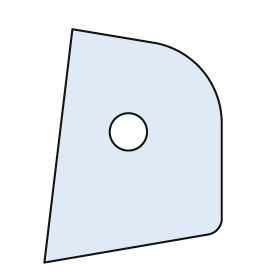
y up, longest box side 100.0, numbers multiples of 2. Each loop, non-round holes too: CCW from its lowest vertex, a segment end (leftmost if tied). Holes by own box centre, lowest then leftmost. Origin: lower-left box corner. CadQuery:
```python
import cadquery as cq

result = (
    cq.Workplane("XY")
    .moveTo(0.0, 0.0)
    .lineTo(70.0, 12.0)
    .threePointArc((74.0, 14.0), (76.0, 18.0))
    .lineTo(76.0, 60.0)
    .threePointArc((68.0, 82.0), (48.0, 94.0))
    .lineTo(12.0, 100.0)
    .close()
    .moveTo(36.0, 56.0)
    .circle(8.0)
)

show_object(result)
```